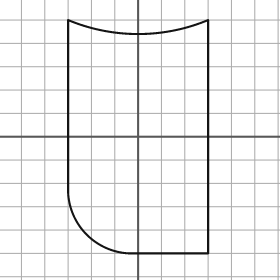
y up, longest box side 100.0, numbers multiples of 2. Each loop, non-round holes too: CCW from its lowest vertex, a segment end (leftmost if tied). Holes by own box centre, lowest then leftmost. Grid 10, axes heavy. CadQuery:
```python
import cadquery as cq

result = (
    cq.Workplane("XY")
    .moveTo(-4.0, -50.0)
    .lineTo(30.0, -50.0)
    .lineTo(30.0, 50.0)
    .threePointArc((0.0, 44.0), (-30.0, 50.0))
    .lineTo(-30.0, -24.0)
    .threePointArc((-22.0, -42.0), (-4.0, -50.0))
    .close()
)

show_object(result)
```